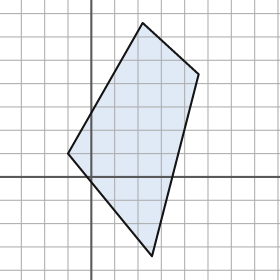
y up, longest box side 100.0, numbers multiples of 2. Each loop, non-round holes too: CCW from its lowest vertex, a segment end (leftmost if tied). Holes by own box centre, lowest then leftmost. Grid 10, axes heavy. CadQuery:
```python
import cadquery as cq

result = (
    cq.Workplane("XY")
    .moveTo(26.0, -34.0)
    .lineTo(46.0, 44.0)
    .lineTo(22.0, 66.0)
    .lineTo(-10.0, 10.0)
    .close()
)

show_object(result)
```